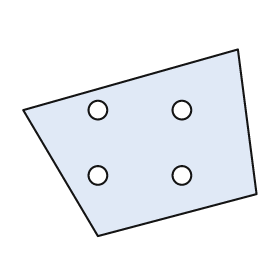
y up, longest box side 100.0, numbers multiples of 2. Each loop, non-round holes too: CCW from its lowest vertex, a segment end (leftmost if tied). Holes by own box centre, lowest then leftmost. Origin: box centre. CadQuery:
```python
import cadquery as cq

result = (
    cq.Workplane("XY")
    .moveTo(-18.0, -40.0)
    .lineTo(50.0, -22.0)
    .lineTo(42.0, 40.0)
    .lineTo(-50.0, 14.0)
    .close()
    .moveTo(-18.0, -14.0)
    .circle(4.0)
    .moveTo(18.0, -14.0)
    .circle(4.0)
    .moveTo(-18.0, 14.0)
    .circle(4.0)
    .moveTo(18.0, 14.0)
    .circle(4.0)
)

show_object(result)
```